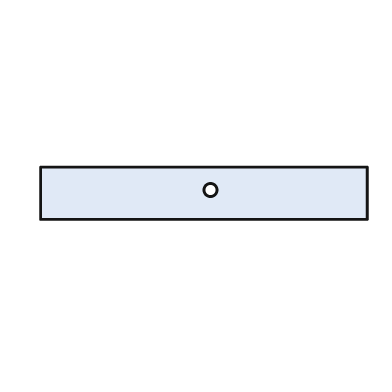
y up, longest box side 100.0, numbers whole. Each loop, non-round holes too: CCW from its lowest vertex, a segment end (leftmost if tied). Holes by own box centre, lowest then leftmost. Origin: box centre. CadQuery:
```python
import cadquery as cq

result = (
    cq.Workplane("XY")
    .moveTo(-50.0, -8.0)
    .lineTo(50.0, -8.0)
    .lineTo(50.0, 8.0)
    .lineTo(-50.0, 8.0)
    .close()
    .moveTo(2.0, 1.0)
    .circle(2.0)
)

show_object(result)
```